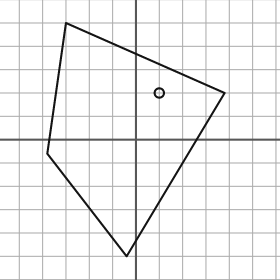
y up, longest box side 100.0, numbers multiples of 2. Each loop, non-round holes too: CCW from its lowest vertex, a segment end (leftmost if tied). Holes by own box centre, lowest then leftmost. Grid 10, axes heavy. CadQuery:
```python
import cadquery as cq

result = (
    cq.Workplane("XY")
    .moveTo(-4.0, -50.0)
    .lineTo(38.0, 20.0)
    .lineTo(-30.0, 50.0)
    .lineTo(-38.0, -6.0)
    .close()
    .moveTo(10.0, 20.0)
    .circle(2.0)
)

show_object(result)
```